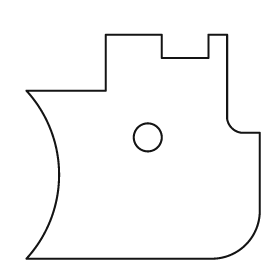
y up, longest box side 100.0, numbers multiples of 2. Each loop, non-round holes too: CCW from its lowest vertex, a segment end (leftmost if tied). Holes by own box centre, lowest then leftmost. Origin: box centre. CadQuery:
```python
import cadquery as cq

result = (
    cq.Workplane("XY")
    .moveTo(-50.0, -48.0)
    .lineTo(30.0, -48.0)
    .threePointArc((44.0, -42.0), (50.0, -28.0))
    .lineTo(50.0, 6.0)
    .lineTo(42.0, 6.0)
    .threePointArc((38.0, 8.0), (36.0, 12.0))
    .lineTo(36.0, 48.0)
    .lineTo(28.0, 48.0)
    .lineTo(28.0, 38.0)
    .lineTo(8.0, 38.0)
    .lineTo(8.0, 48.0)
    .lineTo(-16.0, 48.0)
    .lineTo(-16.0, 24.0)
    .lineTo(-50.0, 24.0)
    .threePointArc((-36.0, -12.0), (-50.0, -48.0))
    .close()
    .moveTo(2.0, 4.0)
    .circle(6.0)
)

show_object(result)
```